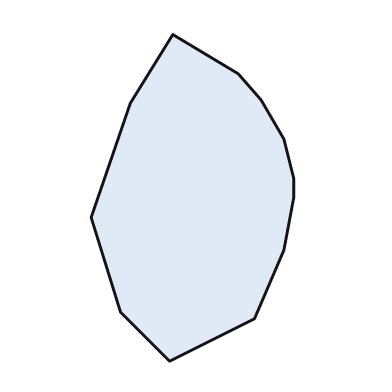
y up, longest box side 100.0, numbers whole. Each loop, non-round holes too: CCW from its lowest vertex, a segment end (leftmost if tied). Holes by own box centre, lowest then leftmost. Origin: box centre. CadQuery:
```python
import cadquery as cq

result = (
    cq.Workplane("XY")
    .moveTo(-7.0, -50.0)
    .lineTo(19.0, -37.0)
    .lineTo(28.0, -16.0)
    .lineTo(31.0, 0.0)
    .lineTo(31.0, 6.0)
    .lineTo(28.0, 18.0)
    .lineTo(21.0, 30.0)
    .lineTo(14.0, 38.0)
    .lineTo(-6.0, 50.0)
    .lineTo(-19.0, 29.0)
    .lineTo(-31.0, -6.0)
    .lineTo(-22.0, -35.0)
    .close()
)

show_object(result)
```